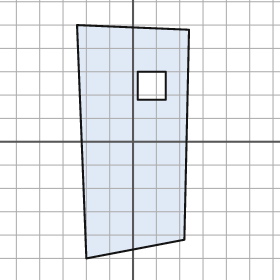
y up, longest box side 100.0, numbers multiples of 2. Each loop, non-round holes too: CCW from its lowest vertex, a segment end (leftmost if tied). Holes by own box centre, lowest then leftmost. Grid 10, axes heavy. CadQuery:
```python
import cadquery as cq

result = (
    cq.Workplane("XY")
    .moveTo(-20.0, -50.0)
    .lineTo(22.0, -42.0)
    .lineTo(24.0, 48.0)
    .lineTo(-24.0, 50.0)
    .close()
    .moveTo(2.0, 18.0)
    .lineTo(14.0, 18.0)
    .lineTo(14.0, 30.0)
    .lineTo(2.0, 30.0)
    .close()
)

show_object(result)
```